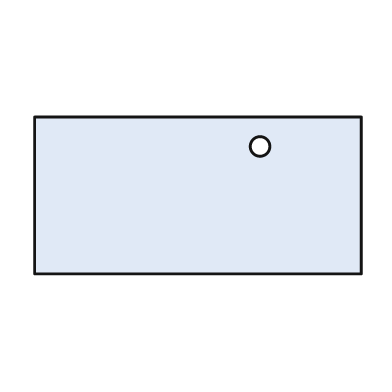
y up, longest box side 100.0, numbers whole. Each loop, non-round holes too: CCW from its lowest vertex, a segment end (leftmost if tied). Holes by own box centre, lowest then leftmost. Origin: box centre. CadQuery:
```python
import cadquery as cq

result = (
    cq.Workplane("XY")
    .moveTo(-50.0, -24.0)
    .lineTo(50.0, -24.0)
    .lineTo(50.0, 24.0)
    .lineTo(-50.0, 24.0)
    .close()
    .moveTo(19.0, 15.0)
    .circle(3.0)
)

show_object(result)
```